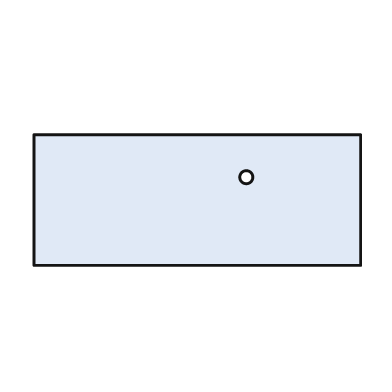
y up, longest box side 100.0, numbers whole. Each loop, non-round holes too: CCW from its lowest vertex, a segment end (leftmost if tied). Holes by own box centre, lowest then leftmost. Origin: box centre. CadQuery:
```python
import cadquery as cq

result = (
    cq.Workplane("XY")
    .moveTo(-50.0, -20.0)
    .lineTo(50.0, -20.0)
    .lineTo(50.0, 20.0)
    .lineTo(-50.0, 20.0)
    .close()
    .moveTo(15.0, 7.0)
    .circle(2.0)
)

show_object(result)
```